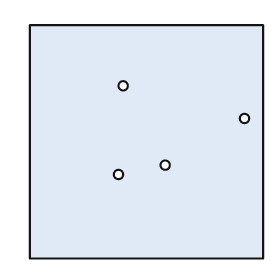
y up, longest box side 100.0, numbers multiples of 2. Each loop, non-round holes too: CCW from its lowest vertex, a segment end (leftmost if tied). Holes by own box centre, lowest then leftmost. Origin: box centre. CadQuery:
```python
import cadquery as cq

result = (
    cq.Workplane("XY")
    .moveTo(-50.0, -50.0)
    .lineTo(50.0, -50.0)
    .lineTo(50.0, 50.0)
    .lineTo(-50.0, 50.0)
    .close()
    .moveTo(-12.0, -14.0)
    .circle(2.0)
    .moveTo(8.0, -10.0)
    .circle(2.0)
    .moveTo(42.0, 10.0)
    .circle(2.0)
    .moveTo(-10.0, 24.0)
    .circle(2.0)
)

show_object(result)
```